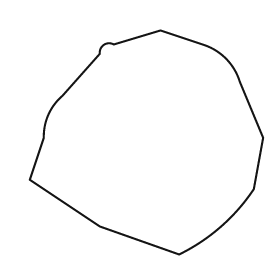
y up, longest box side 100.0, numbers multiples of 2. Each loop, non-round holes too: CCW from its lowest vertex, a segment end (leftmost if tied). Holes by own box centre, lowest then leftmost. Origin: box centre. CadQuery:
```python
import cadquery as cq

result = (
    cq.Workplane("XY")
    .moveTo(14.0, -48.0)
    .threePointArc((32.0, -36.0), (46.0, -20.0))
    .lineTo(50.0, 2.0)
    .lineTo(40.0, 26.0)
    .threePointArc((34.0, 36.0), (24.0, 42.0))
    .lineTo(6.0, 48.0)
    .lineTo(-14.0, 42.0)
    .threePointArc((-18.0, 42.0), (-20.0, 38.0))
    .lineTo(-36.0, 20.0)
    .threePointArc((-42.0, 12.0), (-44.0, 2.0))
    .lineTo(-50.0, -16.0)
    .lineTo(-20.0, -36.0)
    .close()
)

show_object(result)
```